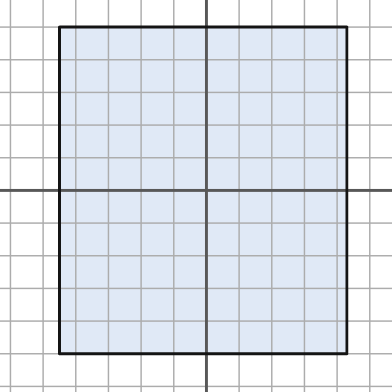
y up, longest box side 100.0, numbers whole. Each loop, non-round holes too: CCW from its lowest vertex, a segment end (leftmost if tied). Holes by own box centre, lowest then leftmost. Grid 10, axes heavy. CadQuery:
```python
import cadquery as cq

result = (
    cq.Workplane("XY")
    .moveTo(-45.0, -50.0)
    .lineTo(43.0, -50.0)
    .lineTo(43.0, 50.0)
    .lineTo(-45.0, 50.0)
    .close()
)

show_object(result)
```